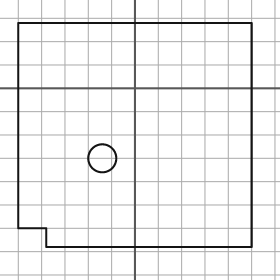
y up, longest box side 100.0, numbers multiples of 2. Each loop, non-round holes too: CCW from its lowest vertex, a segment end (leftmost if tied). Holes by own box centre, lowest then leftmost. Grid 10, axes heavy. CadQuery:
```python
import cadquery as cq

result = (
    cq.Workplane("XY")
    .moveTo(-38.0, -68.0)
    .lineTo(50.0, -68.0)
    .lineTo(50.0, 28.0)
    .lineTo(-50.0, 28.0)
    .lineTo(-50.0, -60.0)
    .lineTo(-38.0, -60.0)
    .close()
    .moveTo(-14.0, -30.0)
    .circle(6.0)
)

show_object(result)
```